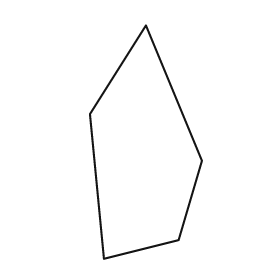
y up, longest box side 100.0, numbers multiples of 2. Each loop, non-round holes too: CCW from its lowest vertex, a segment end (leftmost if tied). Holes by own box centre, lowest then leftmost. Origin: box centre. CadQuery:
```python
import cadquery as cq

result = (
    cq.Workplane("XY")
    .moveTo(-18.0, -50.0)
    .lineTo(14.0, -42.0)
    .lineTo(24.0, -8.0)
    .lineTo(0.0, 50.0)
    .lineTo(-24.0, 12.0)
    .close()
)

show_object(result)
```